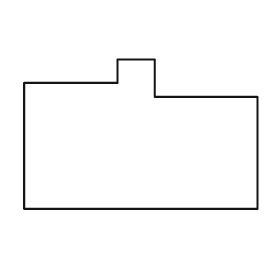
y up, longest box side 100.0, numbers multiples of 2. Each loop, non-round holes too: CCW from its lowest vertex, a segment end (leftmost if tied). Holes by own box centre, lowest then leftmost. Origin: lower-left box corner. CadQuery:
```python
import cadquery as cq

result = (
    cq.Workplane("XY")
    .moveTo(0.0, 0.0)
    .lineTo(100.0, 0.0)
    .lineTo(100.0, 48.0)
    .lineTo(56.0, 48.0)
    .lineTo(56.0, 64.0)
    .lineTo(40.0, 64.0)
    .lineTo(40.0, 54.0)
    .lineTo(0.0, 54.0)
    .close()
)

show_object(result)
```